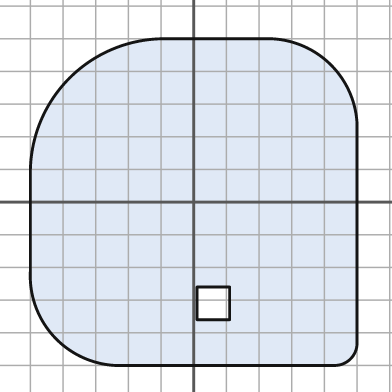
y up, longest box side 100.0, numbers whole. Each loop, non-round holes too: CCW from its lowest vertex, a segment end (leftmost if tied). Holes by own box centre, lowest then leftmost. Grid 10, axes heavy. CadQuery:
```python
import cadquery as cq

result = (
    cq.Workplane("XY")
    .moveTo(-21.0, -50.0)
    .lineTo(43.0, -50.0)
    .threePointArc((48.0, -48.0), (50.0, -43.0))
    .lineTo(50.0, 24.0)
    .threePointArc((42.0, 42.0), (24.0, 50.0))
    .lineTo(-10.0, 50.0)
    .threePointArc((-38.0, 38.0), (-50.0, 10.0))
    .lineTo(-50.0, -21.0)
    .threePointArc((-42.0, -42.0), (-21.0, -50.0))
    .close()
    .moveTo(1.0, -36.0)
    .lineTo(11.0, -36.0)
    .lineTo(11.0, -26.0)
    .lineTo(1.0, -26.0)
    .close()
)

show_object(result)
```